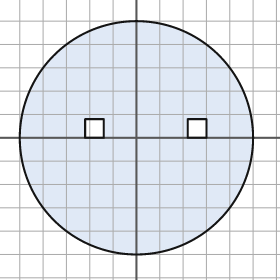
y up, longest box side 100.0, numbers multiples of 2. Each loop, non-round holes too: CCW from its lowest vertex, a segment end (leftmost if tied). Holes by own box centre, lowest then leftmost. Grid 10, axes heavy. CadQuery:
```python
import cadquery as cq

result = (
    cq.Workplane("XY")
    .moveTo(0.0, 0.0)
    .circle(50.0)
    .moveTo(-22.0, 0.0)
    .lineTo(-14.0, 0.0)
    .lineTo(-14.0, 8.0)
    .lineTo(-22.0, 8.0)
    .close()
    .moveTo(22.0, 0.0)
    .lineTo(30.0, 0.0)
    .lineTo(30.0, 8.0)
    .lineTo(22.0, 8.0)
    .close()
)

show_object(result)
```